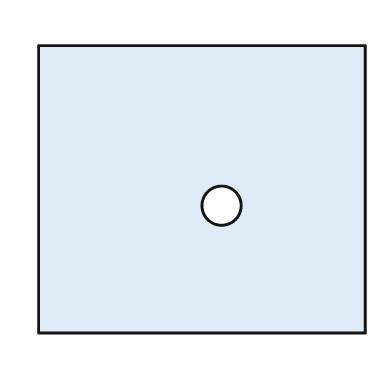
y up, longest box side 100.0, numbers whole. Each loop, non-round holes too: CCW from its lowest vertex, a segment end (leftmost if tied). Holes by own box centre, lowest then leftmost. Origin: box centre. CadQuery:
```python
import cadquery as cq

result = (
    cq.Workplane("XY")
    .moveTo(-50.0, -44.0)
    .lineTo(50.0, -44.0)
    .lineTo(50.0, 44.0)
    .lineTo(-50.0, 44.0)
    .close()
    .moveTo(6.0, -5.0)
    .circle(6.0)
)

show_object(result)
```